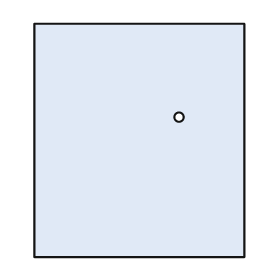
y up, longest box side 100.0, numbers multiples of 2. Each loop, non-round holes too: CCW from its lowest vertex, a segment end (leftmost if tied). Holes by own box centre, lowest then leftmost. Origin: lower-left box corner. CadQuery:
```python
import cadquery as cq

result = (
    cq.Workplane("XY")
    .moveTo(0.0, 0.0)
    .lineTo(90.0, 0.0)
    .lineTo(90.0, 100.0)
    .lineTo(0.0, 100.0)
    .close()
    .moveTo(62.0, 60.0)
    .circle(2.0)
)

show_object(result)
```